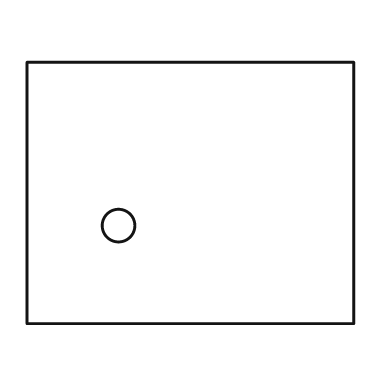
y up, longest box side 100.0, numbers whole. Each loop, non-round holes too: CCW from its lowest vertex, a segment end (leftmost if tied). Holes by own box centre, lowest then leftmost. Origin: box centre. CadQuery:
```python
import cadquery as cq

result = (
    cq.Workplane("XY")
    .moveTo(-50.0, -40.0)
    .lineTo(50.0, -40.0)
    .lineTo(50.0, 40.0)
    .lineTo(-50.0, 40.0)
    .close()
    .moveTo(-22.0, -10.0)
    .circle(5.0)
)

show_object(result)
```